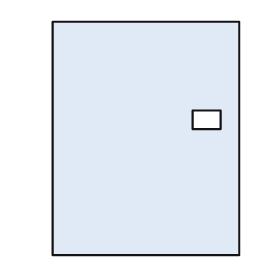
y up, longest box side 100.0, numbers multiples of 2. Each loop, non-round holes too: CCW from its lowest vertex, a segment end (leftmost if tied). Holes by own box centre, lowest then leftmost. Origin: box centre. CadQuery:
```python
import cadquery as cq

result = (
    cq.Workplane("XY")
    .moveTo(-40.0, -50.0)
    .lineTo(40.0, -50.0)
    .lineTo(40.0, 50.0)
    .lineTo(-40.0, 50.0)
    .close()
    .moveTo(20.0, 4.0)
    .lineTo(32.0, 4.0)
    .lineTo(32.0, 12.0)
    .lineTo(20.0, 12.0)
    .close()
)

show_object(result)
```